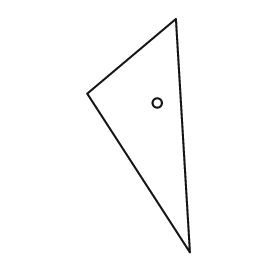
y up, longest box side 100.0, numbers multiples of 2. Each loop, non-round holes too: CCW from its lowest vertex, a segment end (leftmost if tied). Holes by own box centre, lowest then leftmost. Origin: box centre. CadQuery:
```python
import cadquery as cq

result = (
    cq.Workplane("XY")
    .moveTo(22.0, -50.0)
    .lineTo(16.0, 50.0)
    .lineTo(-22.0, 18.0)
    .close()
    .moveTo(8.0, 14.0)
    .circle(2.0)
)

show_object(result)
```